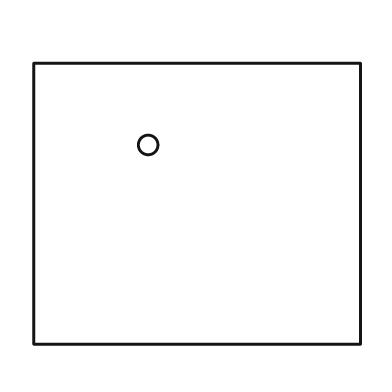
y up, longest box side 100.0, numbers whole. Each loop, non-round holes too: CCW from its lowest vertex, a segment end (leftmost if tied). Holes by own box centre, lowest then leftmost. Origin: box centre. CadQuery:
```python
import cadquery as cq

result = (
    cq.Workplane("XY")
    .moveTo(-50.0, -43.0)
    .lineTo(50.0, -43.0)
    .lineTo(50.0, 43.0)
    .lineTo(-50.0, 43.0)
    .close()
    .moveTo(-15.0, 18.0)
    .circle(3.0)
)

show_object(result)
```